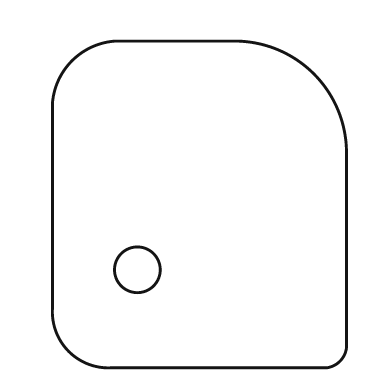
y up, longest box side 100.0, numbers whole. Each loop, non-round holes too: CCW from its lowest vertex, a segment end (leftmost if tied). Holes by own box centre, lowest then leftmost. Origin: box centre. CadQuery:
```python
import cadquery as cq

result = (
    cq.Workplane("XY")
    .moveTo(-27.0, -50.0)
    .lineTo(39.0, -50.0)
    .threePointArc((43.0, -48.0), (45.0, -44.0))
    .lineTo(45.0, 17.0)
    .threePointArc((35.0, 40.0), (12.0, 50.0))
    .lineTo(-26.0, 50.0)
    .threePointArc((-39.0, 44.0), (-45.0, 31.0))
    .lineTo(-45.0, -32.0)
    .threePointArc((-40.0, -45.0), (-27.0, -50.0))
    .close()
    .moveTo(-19.0, -20.0)
    .circle(7.0)
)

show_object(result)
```